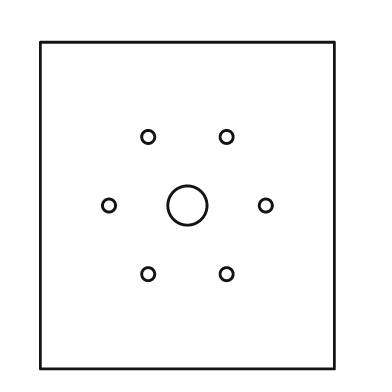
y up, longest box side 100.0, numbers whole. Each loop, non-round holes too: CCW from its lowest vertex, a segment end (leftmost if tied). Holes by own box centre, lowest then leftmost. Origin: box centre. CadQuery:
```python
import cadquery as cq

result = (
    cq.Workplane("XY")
    .moveTo(-45.0, -50.0)
    .lineTo(45.0, -50.0)
    .lineTo(45.0, 50.0)
    .lineTo(-45.0, 50.0)
    .close()
    .moveTo(-12.0, -21.0)
    .circle(2.0)
    .moveTo(12.0, -21.0)
    .circle(2.0)
    .moveTo(-24.0, 0.0)
    .circle(2.0)
    .moveTo(0.0, 0.0)
    .circle(6.0)
    .moveTo(24.0, 0.0)
    .circle(2.0)
    .moveTo(-12.0, 21.0)
    .circle(2.0)
    .moveTo(12.0, 21.0)
    .circle(2.0)
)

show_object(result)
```